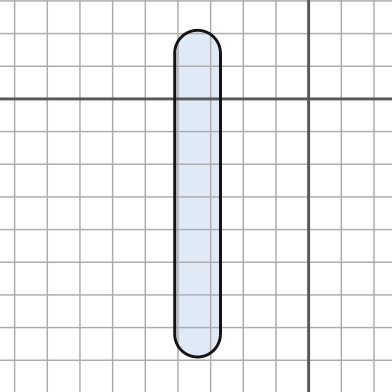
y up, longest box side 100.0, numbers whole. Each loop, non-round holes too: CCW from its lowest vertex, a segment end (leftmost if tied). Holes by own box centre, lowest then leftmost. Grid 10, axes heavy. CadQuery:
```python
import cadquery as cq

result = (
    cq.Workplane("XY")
    .moveTo(-41.0, -72.0)
    .threePointArc((-34.0, -79.0), (-27.0, -72.0))
    .lineTo(-27.0, 14.0)
    .threePointArc((-34.0, 21.0), (-41.0, 14.0))
    .close()
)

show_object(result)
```